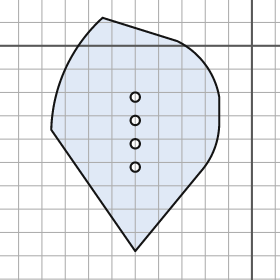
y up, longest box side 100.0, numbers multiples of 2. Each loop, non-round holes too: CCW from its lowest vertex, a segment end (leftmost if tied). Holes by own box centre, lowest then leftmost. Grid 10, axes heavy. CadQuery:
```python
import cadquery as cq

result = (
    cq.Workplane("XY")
    .moveTo(-50.0, -88.0)
    .lineTo(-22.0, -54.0)
    .threePointArc((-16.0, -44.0), (-14.0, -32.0))
    .lineTo(-14.0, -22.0)
    .threePointArc((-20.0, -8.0), (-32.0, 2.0))
    .lineTo(-64.0, 12.0)
    .threePointArc((-80.0, -10.0), (-86.0, -36.0))
    .close()
    .moveTo(-50.0, -52.0)
    .circle(2.0)
    .moveTo(-50.0, -42.0)
    .circle(2.0)
    .moveTo(-50.0, -32.0)
    .circle(2.0)
    .moveTo(-50.0, -22.0)
    .circle(2.0)
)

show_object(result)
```